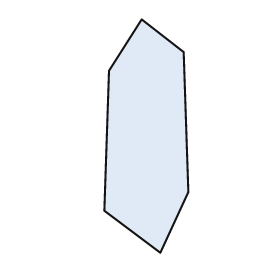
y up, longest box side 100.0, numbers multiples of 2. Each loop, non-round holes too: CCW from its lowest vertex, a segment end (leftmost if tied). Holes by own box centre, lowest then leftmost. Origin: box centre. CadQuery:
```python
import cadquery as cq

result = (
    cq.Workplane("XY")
    .moveTo(6.0, -50.0)
    .lineTo(18.0, -24.0)
    .lineTo(16.0, 36.0)
    .lineTo(-2.0, 50.0)
    .lineTo(-16.0, 28.0)
    .lineTo(-18.0, -32.0)
    .close()
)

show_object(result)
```